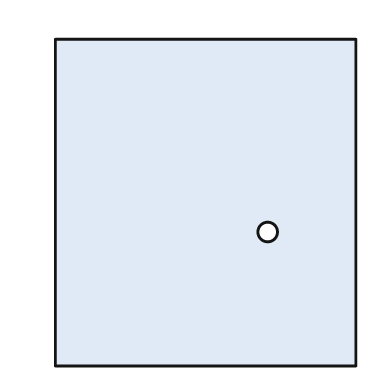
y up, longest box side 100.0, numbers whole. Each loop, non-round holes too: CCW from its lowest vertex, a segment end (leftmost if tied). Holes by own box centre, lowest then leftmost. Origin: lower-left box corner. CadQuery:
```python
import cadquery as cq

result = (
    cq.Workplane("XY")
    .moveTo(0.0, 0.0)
    .lineTo(92.0, 0.0)
    .lineTo(92.0, 100.0)
    .lineTo(0.0, 100.0)
    .close()
    .moveTo(65.0, 41.0)
    .circle(3.0)
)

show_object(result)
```